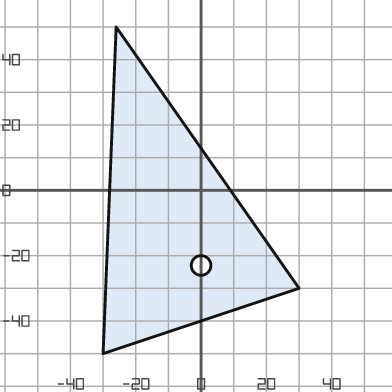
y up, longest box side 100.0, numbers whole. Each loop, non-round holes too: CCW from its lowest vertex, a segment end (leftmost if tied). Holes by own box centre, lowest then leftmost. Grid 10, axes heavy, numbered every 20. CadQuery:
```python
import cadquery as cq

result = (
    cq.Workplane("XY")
    .moveTo(-30.0, -50.0)
    .lineTo(30.0, -30.0)
    .lineTo(-26.0, 50.0)
    .close()
    .moveTo(0.0, -23.0)
    .circle(3.0)
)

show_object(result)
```